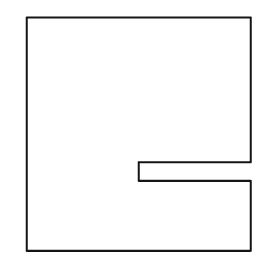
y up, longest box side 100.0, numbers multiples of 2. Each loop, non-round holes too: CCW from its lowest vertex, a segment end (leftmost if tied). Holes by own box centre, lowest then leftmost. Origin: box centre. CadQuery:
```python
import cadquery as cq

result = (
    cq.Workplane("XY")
    .moveTo(-48.0, -50.0)
    .lineTo(48.0, -50.0)
    .lineTo(48.0, -20.0)
    .lineTo(0.0, -20.0)
    .lineTo(0.0, -12.0)
    .lineTo(48.0, -12.0)
    .lineTo(48.0, 50.0)
    .lineTo(-48.0, 50.0)
    .close()
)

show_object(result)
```